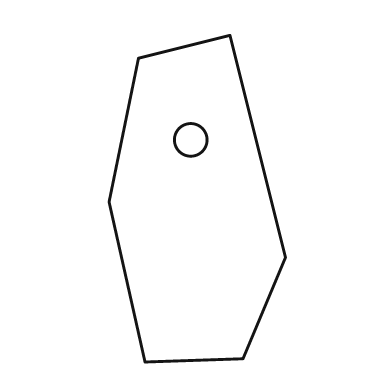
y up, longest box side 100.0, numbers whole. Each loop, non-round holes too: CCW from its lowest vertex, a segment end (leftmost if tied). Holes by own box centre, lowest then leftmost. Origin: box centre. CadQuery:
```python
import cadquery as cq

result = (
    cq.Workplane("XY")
    .moveTo(-16.0, -50.0)
    .lineTo(14.0, -49.0)
    .lineTo(27.0, -18.0)
    .lineTo(10.0, 50.0)
    .lineTo(-18.0, 43.0)
    .lineTo(-27.0, -1.0)
    .close()
    .moveTo(-2.0, 18.0)
    .circle(5.0)
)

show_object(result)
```